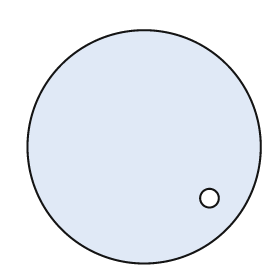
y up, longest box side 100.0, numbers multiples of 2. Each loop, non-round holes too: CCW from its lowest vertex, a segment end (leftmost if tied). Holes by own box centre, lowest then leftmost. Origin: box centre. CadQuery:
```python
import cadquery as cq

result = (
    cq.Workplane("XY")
    .moveTo(0.0, 0.0)
    .circle(50.0)
    .moveTo(28.0, -22.0)
    .circle(4.0)
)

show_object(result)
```